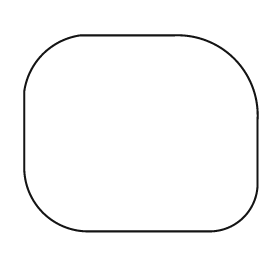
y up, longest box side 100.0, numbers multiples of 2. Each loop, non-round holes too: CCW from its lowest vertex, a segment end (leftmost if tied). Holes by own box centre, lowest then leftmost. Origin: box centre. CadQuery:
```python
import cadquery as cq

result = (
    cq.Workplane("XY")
    .moveTo(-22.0, -42.0)
    .lineTo(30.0, -42.0)
    .threePointArc((44.0, -36.0), (50.0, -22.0))
    .lineTo(50.0, 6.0)
    .threePointArc((40.0, 32.0), (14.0, 42.0))
    .lineTo(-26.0, 42.0)
    .threePointArc((-42.0, 34.0), (-50.0, 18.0))
    .lineTo(-50.0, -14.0)
    .threePointArc((-42.0, -34.0), (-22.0, -42.0))
    .close()
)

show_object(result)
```